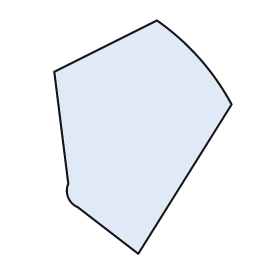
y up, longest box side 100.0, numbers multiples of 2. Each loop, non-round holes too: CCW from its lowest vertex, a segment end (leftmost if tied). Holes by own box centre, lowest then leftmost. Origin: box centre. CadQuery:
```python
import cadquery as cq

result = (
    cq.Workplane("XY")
    .moveTo(-2.0, -50.0)
    .lineTo(38.0, 14.0)
    .threePointArc((24.0, 34.0), (6.0, 50.0))
    .lineTo(-38.0, 28.0)
    .lineTo(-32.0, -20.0)
    .threePointArc((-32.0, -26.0), (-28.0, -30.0))
    .close()
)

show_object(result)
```